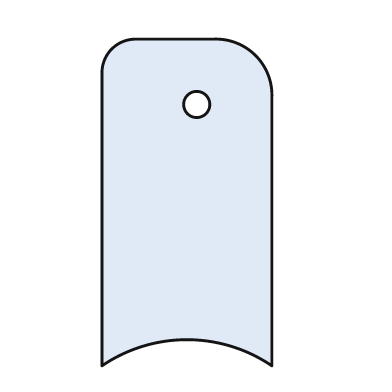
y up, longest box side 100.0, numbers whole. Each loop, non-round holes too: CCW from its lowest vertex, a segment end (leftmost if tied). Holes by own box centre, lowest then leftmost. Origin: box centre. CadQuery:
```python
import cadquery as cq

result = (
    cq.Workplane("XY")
    .moveTo(-26.0, -50.0)
    .threePointArc((0.0, -42.0), (26.0, -50.0))
    .lineTo(26.0, 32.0)
    .threePointArc((21.0, 45.0), (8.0, 50.0))
    .lineTo(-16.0, 50.0)
    .threePointArc((-23.0, 47.0), (-26.0, 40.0))
    .close()
    .moveTo(3.0, 30.0)
    .circle(4.0)
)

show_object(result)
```